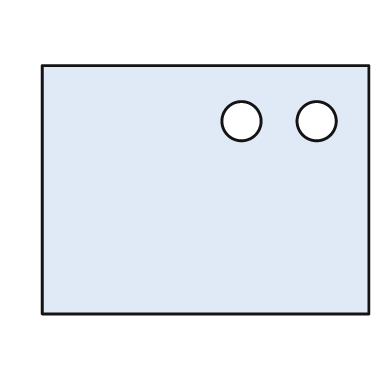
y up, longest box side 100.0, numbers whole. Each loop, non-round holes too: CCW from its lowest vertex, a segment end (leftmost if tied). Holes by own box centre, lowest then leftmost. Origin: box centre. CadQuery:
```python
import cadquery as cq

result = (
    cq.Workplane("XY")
    .moveTo(-50.0, -38.0)
    .lineTo(50.0, -38.0)
    .lineTo(50.0, 38.0)
    .lineTo(-50.0, 38.0)
    .close()
    .moveTo(11.0, 21.0)
    .circle(6.0)
    .moveTo(34.0, 21.0)
    .circle(6.0)
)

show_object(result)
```